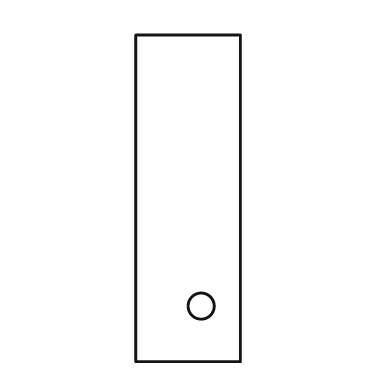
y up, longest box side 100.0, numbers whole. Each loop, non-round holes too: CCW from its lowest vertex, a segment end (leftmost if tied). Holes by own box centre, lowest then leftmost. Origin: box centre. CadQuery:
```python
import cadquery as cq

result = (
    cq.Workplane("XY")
    .moveTo(-16.0, -50.0)
    .lineTo(16.0, -50.0)
    .lineTo(16.0, 50.0)
    .lineTo(-16.0, 50.0)
    .close()
    .moveTo(4.0, -33.0)
    .circle(4.0)
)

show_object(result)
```